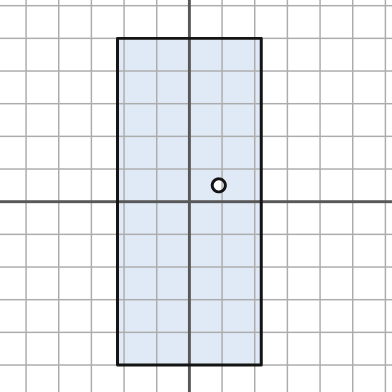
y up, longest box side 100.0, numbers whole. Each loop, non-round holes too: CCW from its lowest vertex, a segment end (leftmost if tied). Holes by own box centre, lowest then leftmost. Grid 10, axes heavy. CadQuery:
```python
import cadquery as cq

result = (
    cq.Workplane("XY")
    .moveTo(-22.0, -50.0)
    .lineTo(22.0, -50.0)
    .lineTo(22.0, 50.0)
    .lineTo(-22.0, 50.0)
    .close()
    .moveTo(9.0, 5.0)
    .circle(2.0)
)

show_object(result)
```